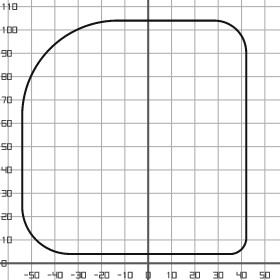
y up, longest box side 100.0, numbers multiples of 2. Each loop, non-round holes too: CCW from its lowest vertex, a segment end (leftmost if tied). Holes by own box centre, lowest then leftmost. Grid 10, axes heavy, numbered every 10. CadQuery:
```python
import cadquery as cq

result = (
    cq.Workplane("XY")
    .moveTo(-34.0, 4.0)
    .lineTo(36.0, 4.0)
    .threePointArc((40.0, 6.0), (42.0, 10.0))
    .lineTo(42.0, 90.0)
    .threePointArc((38.0, 100.0), (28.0, 104.0))
    .lineTo(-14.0, 104.0)
    .threePointArc((-42.0, 92.0), (-54.0, 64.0))
    .lineTo(-54.0, 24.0)
    .threePointArc((-48.0, 10.0), (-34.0, 4.0))
    .close()
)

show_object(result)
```